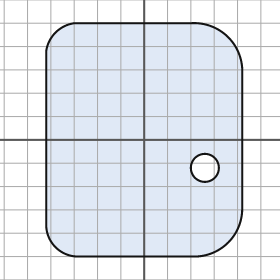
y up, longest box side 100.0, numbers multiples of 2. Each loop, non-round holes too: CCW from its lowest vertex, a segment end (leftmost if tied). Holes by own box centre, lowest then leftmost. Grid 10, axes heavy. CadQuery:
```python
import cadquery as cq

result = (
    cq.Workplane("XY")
    .moveTo(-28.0, -50.0)
    .lineTo(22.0, -50.0)
    .threePointArc((36.0, -44.0), (42.0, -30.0))
    .lineTo(42.0, 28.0)
    .threePointArc((36.0, 44.0), (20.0, 50.0))
    .lineTo(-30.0, 50.0)
    .threePointArc((-38.0, 46.0), (-42.0, 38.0))
    .lineTo(-42.0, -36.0)
    .threePointArc((-38.0, -46.0), (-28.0, -50.0))
    .close()
    .moveTo(26.0, -12.0)
    .circle(6.0)
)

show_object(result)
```